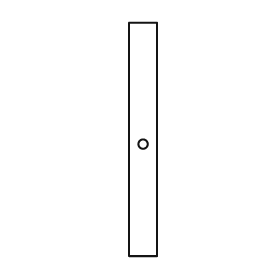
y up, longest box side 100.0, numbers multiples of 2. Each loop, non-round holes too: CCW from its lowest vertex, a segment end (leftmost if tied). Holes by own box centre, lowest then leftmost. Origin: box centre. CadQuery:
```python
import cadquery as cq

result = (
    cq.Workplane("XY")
    .moveTo(-6.0, -50.0)
    .lineTo(6.0, -50.0)
    .lineTo(6.0, 50.0)
    .lineTo(-6.0, 50.0)
    .close()
    .moveTo(0.0, -2.0)
    .circle(2.0)
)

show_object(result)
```